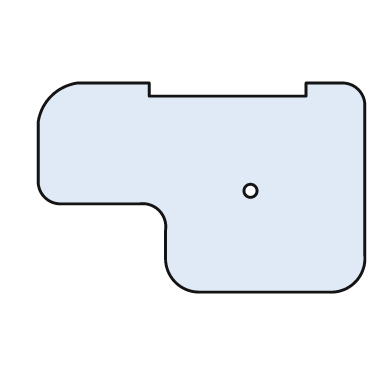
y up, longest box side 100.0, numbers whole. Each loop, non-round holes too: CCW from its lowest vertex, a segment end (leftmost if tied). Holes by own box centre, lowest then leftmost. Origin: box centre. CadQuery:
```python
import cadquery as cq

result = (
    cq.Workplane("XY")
    .moveTo(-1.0, -32.0)
    .lineTo(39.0, -32.0)
    .threePointArc((47.0, -29.0), (50.0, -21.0))
    .lineTo(50.0, 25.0)
    .threePointArc((48.0, 30.0), (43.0, 32.0))
    .lineTo(32.0, 32.0)
    .lineTo(32.0, 28.0)
    .lineTo(-16.0, 28.0)
    .lineTo(-16.0, 32.0)
    .lineTo(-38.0, 32.0)
    .threePointArc((-46.0, 28.0), (-50.0, 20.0))
    .lineTo(-50.0, 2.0)
    .threePointArc((-48.0, -3.0), (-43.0, -5.0))
    .lineTo(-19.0, -5.0)
    .threePointArc((-13.0, -7.0), (-11.0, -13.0))
    .lineTo(-11.0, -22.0)
    .threePointArc((-8.0, -29.0), (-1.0, -32.0))
    .close()
    .moveTo(15.0, -1.0)
    .circle(2.0)
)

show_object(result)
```